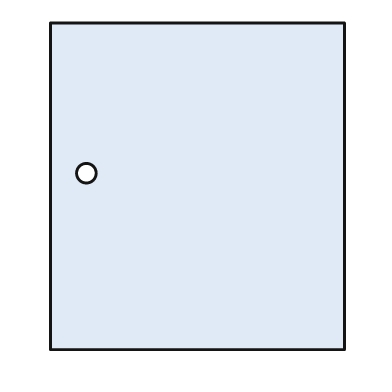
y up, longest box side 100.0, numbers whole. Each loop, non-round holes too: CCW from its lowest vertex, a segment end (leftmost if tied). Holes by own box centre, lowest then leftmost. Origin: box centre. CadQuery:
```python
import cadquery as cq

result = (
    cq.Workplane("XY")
    .moveTo(-45.0, -50.0)
    .lineTo(45.0, -50.0)
    .lineTo(45.0, 50.0)
    .lineTo(-45.0, 50.0)
    .close()
    .moveTo(-34.0, 4.0)
    .circle(3.0)
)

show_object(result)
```